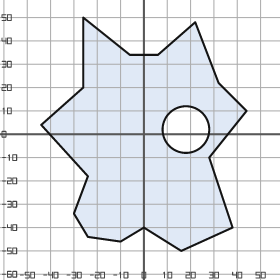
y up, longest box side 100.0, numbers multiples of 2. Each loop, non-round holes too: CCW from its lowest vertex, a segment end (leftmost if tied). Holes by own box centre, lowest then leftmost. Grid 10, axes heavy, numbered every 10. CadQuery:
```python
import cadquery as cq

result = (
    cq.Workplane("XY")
    .moveTo(16.0, -50.0)
    .lineTo(38.0, -40.0)
    .lineTo(28.0, -10.0)
    .lineTo(44.0, 10.0)
    .lineTo(32.0, 22.0)
    .lineTo(22.0, 48.0)
    .lineTo(6.0, 34.0)
    .lineTo(-6.0, 34.0)
    .lineTo(-26.0, 50.0)
    .lineTo(-26.0, 20.0)
    .lineTo(-44.0, 4.0)
    .lineTo(-24.0, -18.0)
    .lineTo(-30.0, -34.0)
    .lineTo(-24.0, -44.0)
    .lineTo(-10.0, -46.0)
    .lineTo(0.0, -40.0)
    .close()
    .moveTo(18.0, 2.0)
    .circle(10.0)
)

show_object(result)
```